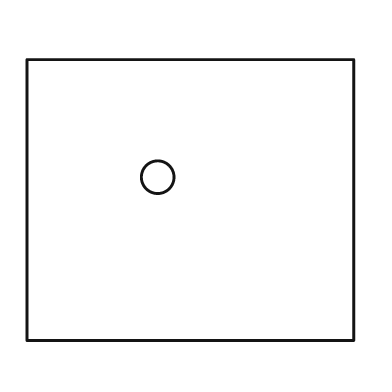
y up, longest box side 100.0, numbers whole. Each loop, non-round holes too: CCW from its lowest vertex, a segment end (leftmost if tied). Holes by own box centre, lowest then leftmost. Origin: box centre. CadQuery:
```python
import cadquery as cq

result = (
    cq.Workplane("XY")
    .moveTo(-50.0, -43.0)
    .lineTo(50.0, -43.0)
    .lineTo(50.0, 43.0)
    .lineTo(-50.0, 43.0)
    .close()
    .moveTo(-10.0, 7.0)
    .circle(5.0)
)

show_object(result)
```